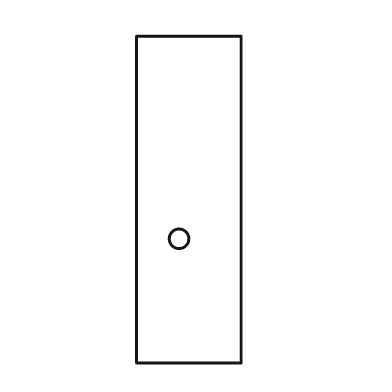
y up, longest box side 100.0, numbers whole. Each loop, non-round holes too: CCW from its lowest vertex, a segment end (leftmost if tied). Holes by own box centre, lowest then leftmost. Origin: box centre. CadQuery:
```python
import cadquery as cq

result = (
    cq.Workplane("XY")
    .moveTo(-16.0, -50.0)
    .lineTo(16.0, -50.0)
    .lineTo(16.0, 50.0)
    .lineTo(-16.0, 50.0)
    .close()
    .moveTo(-3.0, -12.0)
    .circle(3.0)
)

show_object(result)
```